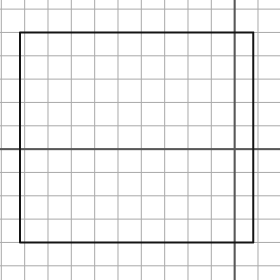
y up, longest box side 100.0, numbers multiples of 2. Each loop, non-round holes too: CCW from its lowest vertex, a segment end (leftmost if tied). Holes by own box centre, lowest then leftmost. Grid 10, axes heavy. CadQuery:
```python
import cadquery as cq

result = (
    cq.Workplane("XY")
    .moveTo(-92.0, -40.0)
    .lineTo(8.0, -40.0)
    .lineTo(8.0, 50.0)
    .lineTo(-92.0, 50.0)
    .close()
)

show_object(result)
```